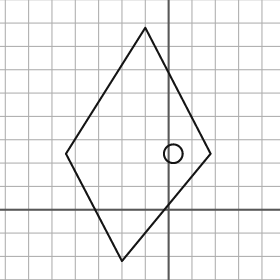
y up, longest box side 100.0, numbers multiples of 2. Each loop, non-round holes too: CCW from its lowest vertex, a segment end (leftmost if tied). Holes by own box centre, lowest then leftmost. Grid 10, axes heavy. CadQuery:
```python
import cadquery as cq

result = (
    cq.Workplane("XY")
    .moveTo(-20.0, -22.0)
    .lineTo(18.0, 24.0)
    .lineTo(-10.0, 78.0)
    .lineTo(-44.0, 24.0)
    .close()
    .moveTo(2.0, 24.0)
    .circle(4.0)
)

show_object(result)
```